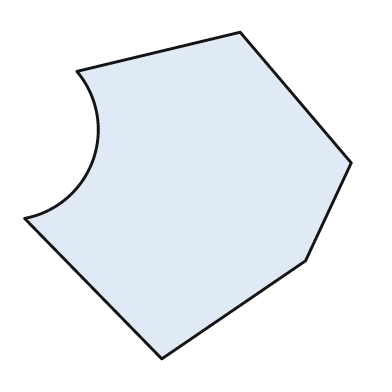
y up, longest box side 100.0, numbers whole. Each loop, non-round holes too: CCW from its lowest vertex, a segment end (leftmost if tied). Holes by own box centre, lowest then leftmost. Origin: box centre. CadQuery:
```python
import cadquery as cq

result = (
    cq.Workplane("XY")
    .moveTo(-8.0, -50.0)
    .lineTo(36.0, -20.0)
    .lineTo(50.0, 10.0)
    .lineTo(16.0, 50.0)
    .lineTo(-34.0, 38.0)
    .threePointArc((-29.0, 11.0), (-50.0, -7.0))
    .close()
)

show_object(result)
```